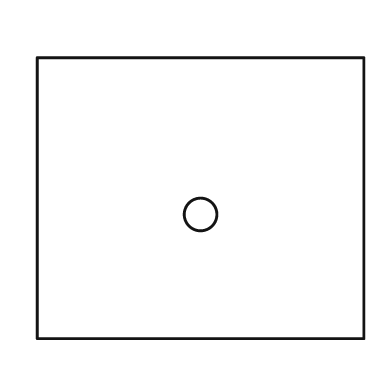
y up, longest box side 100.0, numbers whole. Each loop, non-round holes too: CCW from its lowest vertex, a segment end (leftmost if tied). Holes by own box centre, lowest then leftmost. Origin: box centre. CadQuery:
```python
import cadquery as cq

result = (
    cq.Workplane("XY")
    .moveTo(-50.0, -43.0)
    .lineTo(50.0, -43.0)
    .lineTo(50.0, 43.0)
    .lineTo(-50.0, 43.0)
    .close()
    .moveTo(0.0, -5.0)
    .circle(5.0)
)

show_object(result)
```